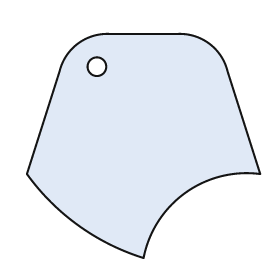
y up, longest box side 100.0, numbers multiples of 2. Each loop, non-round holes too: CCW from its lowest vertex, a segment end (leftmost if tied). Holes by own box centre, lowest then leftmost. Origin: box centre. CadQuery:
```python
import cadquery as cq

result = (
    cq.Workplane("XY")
    .moveTo(0.0, -48.0)
    .threePointArc((18.0, -20.0), (50.0, -12.0))
    .lineTo(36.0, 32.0)
    .threePointArc((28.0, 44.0), (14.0, 48.0))
    .lineTo(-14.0, 48.0)
    .threePointArc((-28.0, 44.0), (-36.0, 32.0))
    .lineTo(-50.0, -12.0)
    .threePointArc((-28.0, -34.0), (0.0, -48.0))
    .close()
    .moveTo(-20.0, 34.0)
    .circle(4.0)
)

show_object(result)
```